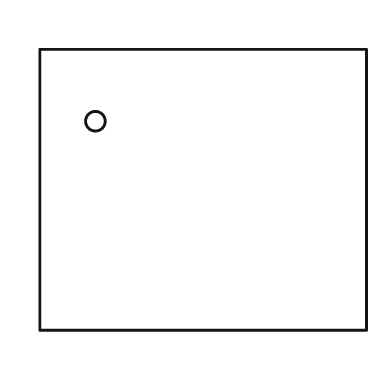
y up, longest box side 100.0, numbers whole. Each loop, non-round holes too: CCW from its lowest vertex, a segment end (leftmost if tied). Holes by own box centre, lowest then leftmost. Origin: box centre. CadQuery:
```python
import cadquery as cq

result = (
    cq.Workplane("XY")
    .moveTo(-50.0, -43.0)
    .lineTo(50.0, -43.0)
    .lineTo(50.0, 43.0)
    .lineTo(-50.0, 43.0)
    .close()
    .moveTo(-33.0, 21.0)
    .circle(3.0)
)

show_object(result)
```